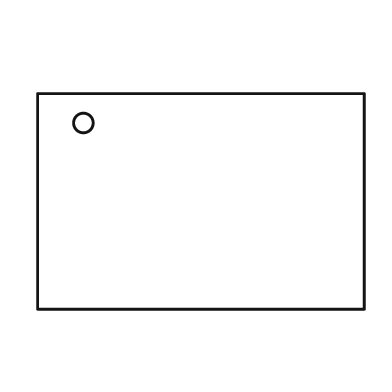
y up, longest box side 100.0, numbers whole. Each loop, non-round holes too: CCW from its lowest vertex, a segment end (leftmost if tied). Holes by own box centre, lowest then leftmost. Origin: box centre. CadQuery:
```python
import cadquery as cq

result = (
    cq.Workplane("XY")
    .moveTo(-50.0, -33.0)
    .lineTo(50.0, -33.0)
    .lineTo(50.0, 33.0)
    .lineTo(-50.0, 33.0)
    .close()
    .moveTo(-36.0, 24.0)
    .circle(3.0)
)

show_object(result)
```